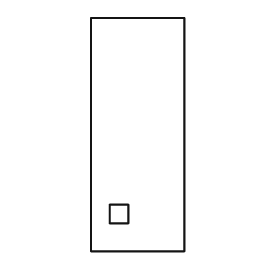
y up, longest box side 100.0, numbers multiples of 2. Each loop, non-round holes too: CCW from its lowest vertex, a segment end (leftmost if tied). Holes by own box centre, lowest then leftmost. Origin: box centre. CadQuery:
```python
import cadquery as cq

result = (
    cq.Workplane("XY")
    .moveTo(-20.0, -50.0)
    .lineTo(20.0, -50.0)
    .lineTo(20.0, 50.0)
    .lineTo(-20.0, 50.0)
    .close()
    .moveTo(-12.0, -38.0)
    .lineTo(-4.0, -38.0)
    .lineTo(-4.0, -30.0)
    .lineTo(-12.0, -30.0)
    .close()
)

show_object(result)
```